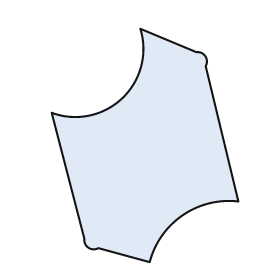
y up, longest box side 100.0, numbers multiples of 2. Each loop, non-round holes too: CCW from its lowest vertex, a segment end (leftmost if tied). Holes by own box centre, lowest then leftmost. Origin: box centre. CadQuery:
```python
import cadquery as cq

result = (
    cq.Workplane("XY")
    .moveTo(2.0, -50.0)
    .threePointArc((16.0, -30.0), (40.0, -24.0))
    .lineTo(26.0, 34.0)
    .threePointArc((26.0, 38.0), (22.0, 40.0))
    .lineTo(-2.0, 50.0)
    .threePointArc((-10.0, 20.0), (-40.0, 14.0))
    .lineTo(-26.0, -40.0)
    .threePointArc((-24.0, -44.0), (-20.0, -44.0))
    .close()
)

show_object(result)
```